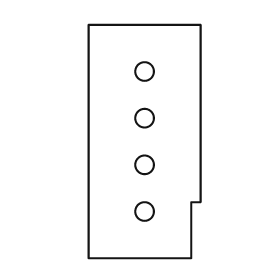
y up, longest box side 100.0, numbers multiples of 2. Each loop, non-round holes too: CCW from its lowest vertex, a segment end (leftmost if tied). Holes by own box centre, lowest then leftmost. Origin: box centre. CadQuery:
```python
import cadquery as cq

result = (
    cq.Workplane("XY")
    .moveTo(-24.0, -50.0)
    .lineTo(20.0, -50.0)
    .lineTo(20.0, -26.0)
    .lineTo(24.0, -26.0)
    .lineTo(24.0, 50.0)
    .lineTo(-24.0, 50.0)
    .close()
    .moveTo(0.0, -30.0)
    .circle(4.0)
    .moveTo(0.0, -10.0)
    .circle(4.0)
    .moveTo(0.0, 10.0)
    .circle(4.0)
    .moveTo(0.0, 30.0)
    .circle(4.0)
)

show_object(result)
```